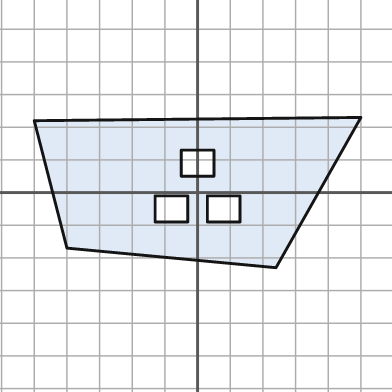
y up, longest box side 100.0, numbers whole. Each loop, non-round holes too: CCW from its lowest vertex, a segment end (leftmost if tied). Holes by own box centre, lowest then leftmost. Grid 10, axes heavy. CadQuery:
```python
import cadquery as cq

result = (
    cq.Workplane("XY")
    .moveTo(24.0, -23.0)
    .lineTo(50.0, 23.0)
    .lineTo(-50.0, 22.0)
    .lineTo(-40.0, -17.0)
    .close()
    .moveTo(-13.0, -9.0)
    .lineTo(-3.0, -9.0)
    .lineTo(-3.0, -1.0)
    .lineTo(-13.0, -1.0)
    .close()
    .moveTo(3.0, -9.0)
    .lineTo(13.0, -9.0)
    .lineTo(13.0, -1.0)
    .lineTo(3.0, -1.0)
    .close()
    .moveTo(-5.0, 5.0)
    .lineTo(5.0, 5.0)
    .lineTo(5.0, 13.0)
    .lineTo(-5.0, 13.0)
    .close()
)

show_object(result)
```